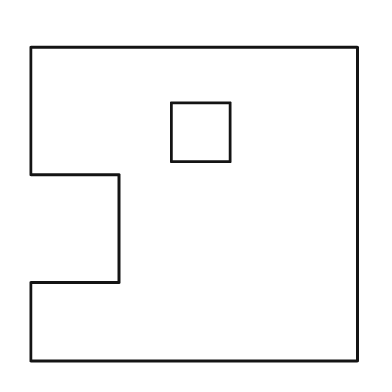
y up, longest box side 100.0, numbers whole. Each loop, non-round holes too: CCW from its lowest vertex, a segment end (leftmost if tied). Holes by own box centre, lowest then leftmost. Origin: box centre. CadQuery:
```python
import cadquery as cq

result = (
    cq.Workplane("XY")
    .moveTo(-50.0, -48.0)
    .lineTo(50.0, -48.0)
    .lineTo(50.0, 48.0)
    .lineTo(-50.0, 48.0)
    .lineTo(-50.0, 9.0)
    .lineTo(-23.0, 9.0)
    .lineTo(-23.0, -24.0)
    .lineTo(-50.0, -24.0)
    .close()
    .moveTo(-7.0, 13.0)
    .lineTo(11.0, 13.0)
    .lineTo(11.0, 31.0)
    .lineTo(-7.0, 31.0)
    .close()
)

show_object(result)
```